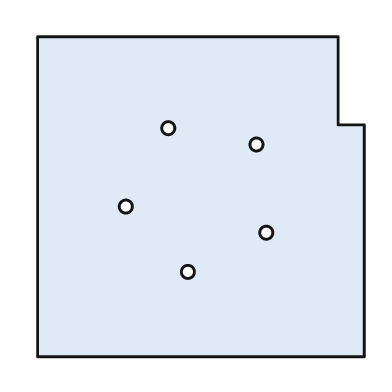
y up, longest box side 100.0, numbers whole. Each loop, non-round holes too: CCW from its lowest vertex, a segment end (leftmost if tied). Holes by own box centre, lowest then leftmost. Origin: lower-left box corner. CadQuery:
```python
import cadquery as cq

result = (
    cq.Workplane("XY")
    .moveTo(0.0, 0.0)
    .lineTo(100.0, 0.0)
    .lineTo(100.0, 71.0)
    .lineTo(92.0, 71.0)
    .lineTo(92.0, 98.0)
    .lineTo(0.0, 98.0)
    .close()
    .moveTo(46.0, 26.0)
    .circle(2.0)
    .moveTo(70.0, 38.0)
    .circle(2.0)
    .moveTo(27.0, 46.0)
    .circle(2.0)
    .moveTo(67.0, 65.0)
    .circle(2.0)
    .moveTo(40.0, 70.0)
    .circle(2.0)
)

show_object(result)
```